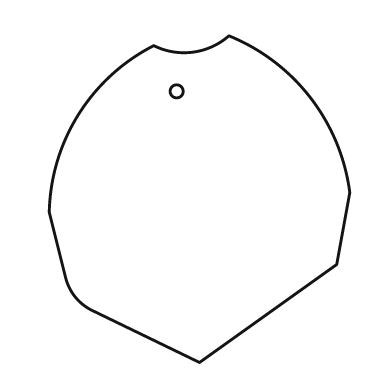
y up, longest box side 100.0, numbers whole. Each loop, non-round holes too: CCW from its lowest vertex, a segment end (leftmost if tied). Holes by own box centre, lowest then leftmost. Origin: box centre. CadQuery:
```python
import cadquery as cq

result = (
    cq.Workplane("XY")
    .moveTo(0.0, -50.0)
    .lineTo(42.0, -20.0)
    .lineTo(46.0, 2.0)
    .threePointArc((34.0, 31.0), (9.0, 50.0))
    .threePointArc((-2.0, 45.0), (-14.0, 47.0))
    .threePointArc((-37.0, 26.0), (-46.0, -4.0))
    .lineTo(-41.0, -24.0)
    .threePointArc((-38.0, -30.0), (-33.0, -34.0))
    .close()
    .moveTo(-7.0, 33.0)
    .circle(2.0)
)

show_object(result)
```